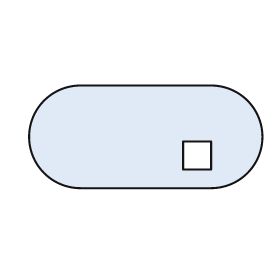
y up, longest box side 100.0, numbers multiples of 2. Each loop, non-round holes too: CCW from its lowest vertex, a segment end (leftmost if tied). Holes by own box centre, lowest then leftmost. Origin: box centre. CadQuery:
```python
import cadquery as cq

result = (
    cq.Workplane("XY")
    .moveTo(-28.0, -22.0)
    .lineTo(28.0, -22.0)
    .threePointArc((50.0, 0.0), (28.0, 22.0))
    .lineTo(-28.0, 22.0)
    .threePointArc((-50.0, 0.0), (-28.0, -22.0))
    .close()
    .moveTo(16.0, -14.0)
    .lineTo(28.0, -14.0)
    .lineTo(28.0, -2.0)
    .lineTo(16.0, -2.0)
    .close()
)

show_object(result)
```